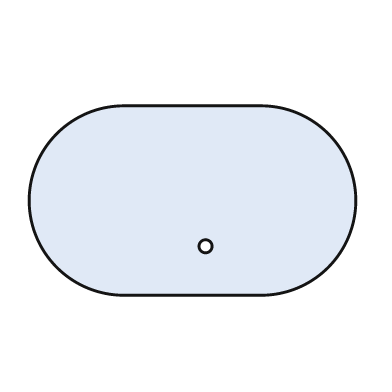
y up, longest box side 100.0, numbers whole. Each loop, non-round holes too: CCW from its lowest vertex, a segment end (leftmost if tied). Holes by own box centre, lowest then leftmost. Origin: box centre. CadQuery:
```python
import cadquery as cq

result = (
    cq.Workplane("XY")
    .moveTo(-21.0, -29.0)
    .lineTo(21.0, -29.0)
    .threePointArc((50.0, 0.0), (21.0, 29.0))
    .lineTo(-21.0, 29.0)
    .threePointArc((-50.0, 0.0), (-21.0, -29.0))
    .close()
    .moveTo(4.0, -14.0)
    .circle(2.0)
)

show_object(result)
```